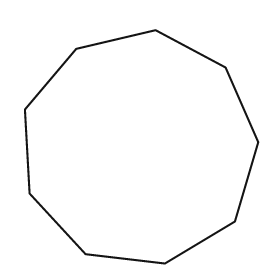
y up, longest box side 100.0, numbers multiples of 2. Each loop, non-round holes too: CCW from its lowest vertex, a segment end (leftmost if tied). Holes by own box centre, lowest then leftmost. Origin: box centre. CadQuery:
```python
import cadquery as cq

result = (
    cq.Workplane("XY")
    .moveTo(10.0, -50.0)
    .lineTo(40.0, -32.0)
    .lineTo(50.0, 2.0)
    .lineTo(36.0, 34.0)
    .lineTo(6.0, 50.0)
    .lineTo(-28.0, 42.0)
    .lineTo(-50.0, 16.0)
    .lineTo(-48.0, -20.0)
    .lineTo(-24.0, -46.0)
    .close()
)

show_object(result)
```